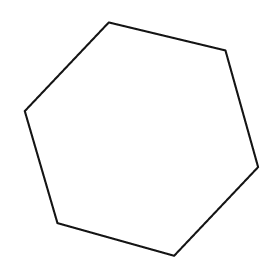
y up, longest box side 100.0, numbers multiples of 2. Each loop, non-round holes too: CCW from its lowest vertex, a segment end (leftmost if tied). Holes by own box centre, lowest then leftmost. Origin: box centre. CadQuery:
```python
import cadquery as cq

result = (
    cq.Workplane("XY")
    .moveTo(14.0, -50.0)
    .lineTo(50.0, -12.0)
    .lineTo(36.0, 38.0)
    .lineTo(-14.0, 50.0)
    .lineTo(-50.0, 12.0)
    .lineTo(-36.0, -36.0)
    .close()
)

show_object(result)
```